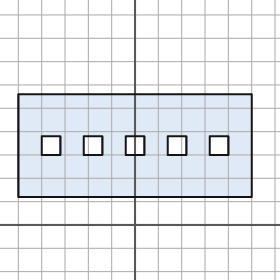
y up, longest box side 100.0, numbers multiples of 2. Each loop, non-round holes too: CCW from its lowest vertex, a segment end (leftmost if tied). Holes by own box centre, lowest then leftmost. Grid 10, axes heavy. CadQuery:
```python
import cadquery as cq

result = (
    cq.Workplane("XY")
    .moveTo(-50.0, 12.0)
    .lineTo(50.0, 12.0)
    .lineTo(50.0, 56.0)
    .lineTo(-50.0, 56.0)
    .close()
    .moveTo(-40.0, 30.0)
    .lineTo(-32.0, 30.0)
    .lineTo(-32.0, 38.0)
    .lineTo(-40.0, 38.0)
    .close()
    .moveTo(-22.0, 30.0)
    .lineTo(-14.0, 30.0)
    .lineTo(-14.0, 38.0)
    .lineTo(-22.0, 38.0)
    .close()
    .moveTo(-4.0, 30.0)
    .lineTo(4.0, 30.0)
    .lineTo(4.0, 38.0)
    .lineTo(-4.0, 38.0)
    .close()
    .moveTo(14.0, 30.0)
    .lineTo(22.0, 30.0)
    .lineTo(22.0, 38.0)
    .lineTo(14.0, 38.0)
    .close()
    .moveTo(32.0, 30.0)
    .lineTo(40.0, 30.0)
    .lineTo(40.0, 38.0)
    .lineTo(32.0, 38.0)
    .close()
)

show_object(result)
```